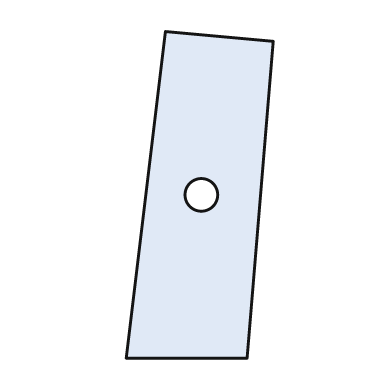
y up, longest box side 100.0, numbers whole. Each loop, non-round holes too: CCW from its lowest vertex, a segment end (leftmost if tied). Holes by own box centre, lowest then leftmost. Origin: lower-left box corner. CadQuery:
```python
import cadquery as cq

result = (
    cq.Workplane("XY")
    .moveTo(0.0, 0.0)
    .lineTo(37.0, 0.0)
    .lineTo(45.0, 97.0)
    .lineTo(12.0, 100.0)
    .close()
    .moveTo(23.0, 50.0)
    .circle(5.0)
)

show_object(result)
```